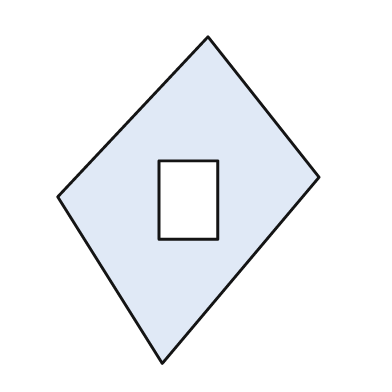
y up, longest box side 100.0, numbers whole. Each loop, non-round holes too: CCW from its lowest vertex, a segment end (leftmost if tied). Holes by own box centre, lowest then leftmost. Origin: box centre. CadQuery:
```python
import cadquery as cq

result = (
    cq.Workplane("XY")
    .moveTo(-8.0, -50.0)
    .lineTo(40.0, 7.0)
    .lineTo(6.0, 50.0)
    .lineTo(-40.0, 1.0)
    .close()
    .moveTo(-9.0, -12.0)
    .lineTo(9.0, -12.0)
    .lineTo(9.0, 12.0)
    .lineTo(-9.0, 12.0)
    .close()
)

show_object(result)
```